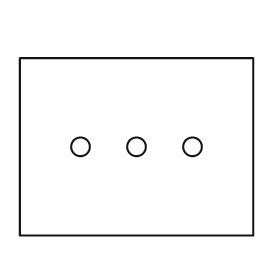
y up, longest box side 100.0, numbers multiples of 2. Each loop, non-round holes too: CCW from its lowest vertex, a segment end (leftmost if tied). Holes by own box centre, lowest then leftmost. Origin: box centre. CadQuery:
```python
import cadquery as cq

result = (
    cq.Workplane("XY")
    .moveTo(-50.0, -38.0)
    .lineTo(50.0, -38.0)
    .lineTo(50.0, 38.0)
    .lineTo(-50.0, 38.0)
    .close()
    .moveTo(-24.0, 0.0)
    .circle(4.0)
    .moveTo(0.0, 0.0)
    .circle(4.0)
    .moveTo(24.0, 0.0)
    .circle(4.0)
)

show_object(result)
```